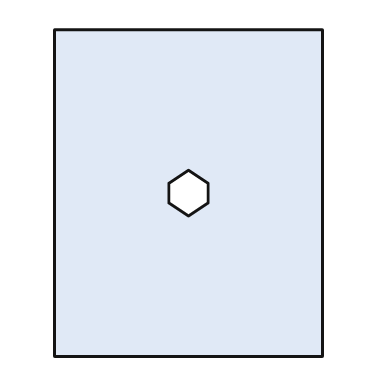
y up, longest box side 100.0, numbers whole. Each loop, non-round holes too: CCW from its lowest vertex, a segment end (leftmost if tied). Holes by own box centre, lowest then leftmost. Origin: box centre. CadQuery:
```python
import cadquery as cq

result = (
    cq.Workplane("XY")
    .moveTo(-41.0, -50.0)
    .lineTo(41.0, -50.0)
    .lineTo(41.0, 50.0)
    .lineTo(-41.0, 50.0)
    .close()
    .moveTo(0.0, -7.0)
    .lineTo(6.0, -3.0)
    .lineTo(6.0, 3.0)
    .lineTo(0.0, 7.0)
    .lineTo(-6.0, 3.0)
    .lineTo(-6.0, -3.0)
    .close()
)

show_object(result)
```